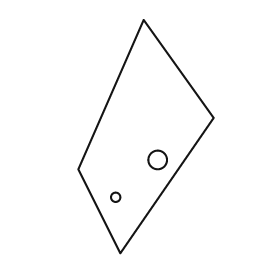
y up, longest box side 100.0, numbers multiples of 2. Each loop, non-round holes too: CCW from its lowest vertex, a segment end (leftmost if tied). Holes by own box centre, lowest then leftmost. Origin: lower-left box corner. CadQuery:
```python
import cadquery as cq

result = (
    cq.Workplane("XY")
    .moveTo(18.0, 0.0)
    .lineTo(58.0, 58.0)
    .lineTo(28.0, 100.0)
    .lineTo(0.0, 36.0)
    .close()
    .moveTo(16.0, 24.0)
    .circle(2.0)
    .moveTo(34.0, 40.0)
    .circle(4.0)
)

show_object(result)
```